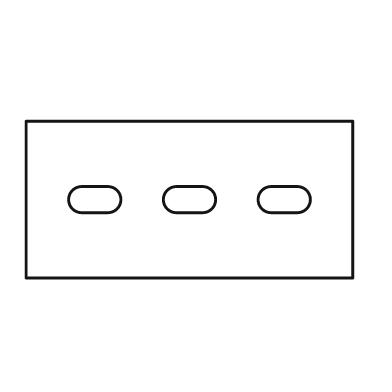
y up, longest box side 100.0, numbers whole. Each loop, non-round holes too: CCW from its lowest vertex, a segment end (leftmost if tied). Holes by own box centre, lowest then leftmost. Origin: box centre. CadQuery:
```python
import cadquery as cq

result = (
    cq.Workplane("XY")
    .moveTo(-50.0, -24.0)
    .lineTo(50.0, -24.0)
    .lineTo(50.0, 24.0)
    .lineTo(-50.0, 24.0)
    .close()
    .moveTo(-33.0, -4.0)
    .lineTo(-25.0, -4.0)
    .threePointArc((-21.0, 0.0), (-25.0, 4.0))
    .lineTo(-33.0, 4.0)
    .threePointArc((-37.0, 0.0), (-33.0, -4.0))
    .close()
    .moveTo(-4.0, -4.0)
    .lineTo(4.0, -4.0)
    .threePointArc((8.0, 0.0), (4.0, 4.0))
    .lineTo(-4.0, 4.0)
    .threePointArc((-8.0, 0.0), (-4.0, -4.0))
    .close()
    .moveTo(25.0, -4.0)
    .lineTo(33.0, -4.0)
    .threePointArc((37.0, 0.0), (33.0, 4.0))
    .lineTo(25.0, 4.0)
    .threePointArc((21.0, 0.0), (25.0, -4.0))
    .close()
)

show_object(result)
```